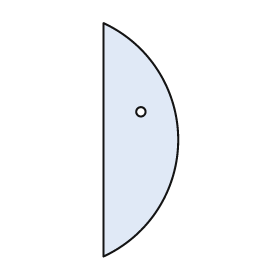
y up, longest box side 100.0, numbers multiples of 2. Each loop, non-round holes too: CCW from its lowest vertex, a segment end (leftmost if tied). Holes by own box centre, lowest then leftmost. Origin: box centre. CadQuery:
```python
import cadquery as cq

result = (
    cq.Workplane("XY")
    .moveTo(-16.0, -50.0)
    .threePointArc((16.0, 0.0), (-16.0, 50.0))
    .close()
    .moveTo(0.0, 12.0)
    .circle(2.0)
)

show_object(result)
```